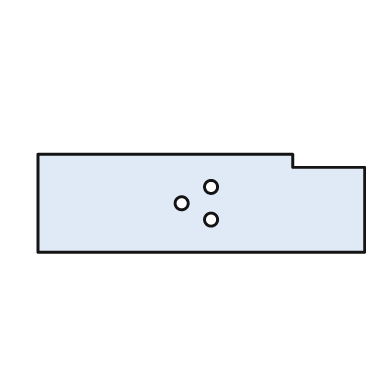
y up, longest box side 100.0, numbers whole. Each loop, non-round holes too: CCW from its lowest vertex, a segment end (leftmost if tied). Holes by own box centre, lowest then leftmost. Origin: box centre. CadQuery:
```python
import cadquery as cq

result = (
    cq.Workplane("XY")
    .moveTo(-50.0, -15.0)
    .lineTo(50.0, -15.0)
    .lineTo(50.0, 11.0)
    .lineTo(28.0, 11.0)
    .lineTo(28.0, 15.0)
    .lineTo(-50.0, 15.0)
    .close()
    .moveTo(3.0, -5.0)
    .circle(2.0)
    .moveTo(-6.0, 0.0)
    .circle(2.0)
    .moveTo(3.0, 5.0)
    .circle(2.0)
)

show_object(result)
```